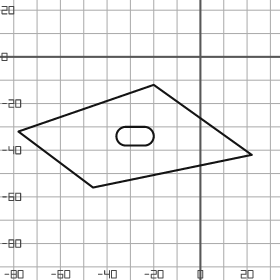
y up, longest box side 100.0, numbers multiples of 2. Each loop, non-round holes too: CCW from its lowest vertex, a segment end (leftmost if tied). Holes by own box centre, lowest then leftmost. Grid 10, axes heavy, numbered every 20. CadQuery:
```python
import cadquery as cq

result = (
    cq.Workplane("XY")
    .moveTo(-46.0, -56.0)
    .lineTo(22.0, -42.0)
    .lineTo(-20.0, -12.0)
    .lineTo(-78.0, -32.0)
    .close()
    .moveTo(-32.0, -38.0)
    .lineTo(-24.0, -38.0)
    .threePointArc((-20.0, -34.0), (-24.0, -30.0))
    .lineTo(-32.0, -30.0)
    .threePointArc((-36.0, -34.0), (-32.0, -38.0))
    .close()
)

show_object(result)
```